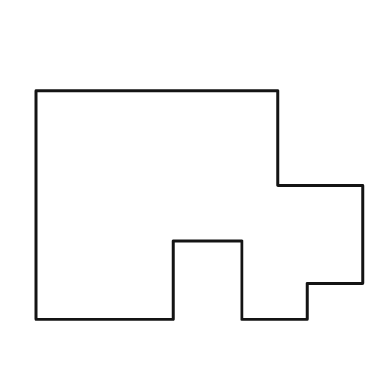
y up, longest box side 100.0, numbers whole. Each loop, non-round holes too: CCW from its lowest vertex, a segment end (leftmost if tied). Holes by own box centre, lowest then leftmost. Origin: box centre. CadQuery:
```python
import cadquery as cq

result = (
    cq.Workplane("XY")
    .moveTo(-50.0, -35.0)
    .lineTo(-8.0, -35.0)
    .lineTo(-8.0, -11.0)
    .lineTo(13.0, -11.0)
    .lineTo(13.0, -35.0)
    .lineTo(33.0, -35.0)
    .lineTo(33.0, -24.0)
    .lineTo(50.0, -24.0)
    .lineTo(50.0, 6.0)
    .lineTo(24.0, 6.0)
    .lineTo(24.0, 35.0)
    .lineTo(-50.0, 35.0)
    .close()
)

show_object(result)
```